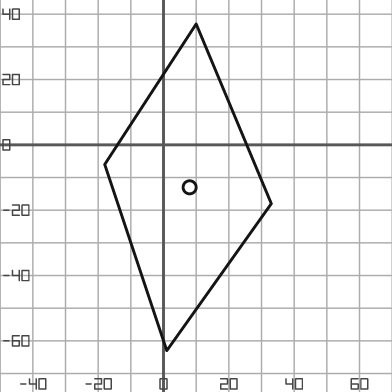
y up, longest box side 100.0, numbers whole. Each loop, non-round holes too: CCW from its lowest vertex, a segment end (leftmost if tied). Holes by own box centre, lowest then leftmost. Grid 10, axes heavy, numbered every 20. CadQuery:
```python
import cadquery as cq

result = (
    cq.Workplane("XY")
    .moveTo(1.0, -63.0)
    .lineTo(33.0, -18.0)
    .lineTo(10.0, 37.0)
    .lineTo(-18.0, -6.0)
    .close()
    .moveTo(8.0, -13.0)
    .circle(2.0)
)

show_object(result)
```